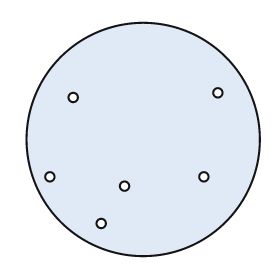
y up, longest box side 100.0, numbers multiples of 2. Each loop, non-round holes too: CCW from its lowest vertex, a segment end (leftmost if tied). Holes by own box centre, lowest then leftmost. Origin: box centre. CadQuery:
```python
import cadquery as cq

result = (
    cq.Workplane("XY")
    .moveTo(0.0, 0.0)
    .circle(50.0)
    .moveTo(-18.0, -36.0)
    .circle(2.0)
    .moveTo(-8.0, -20.0)
    .circle(2.0)
    .moveTo(-40.0, -16.0)
    .circle(2.0)
    .moveTo(26.0, -16.0)
    .circle(2.0)
    .moveTo(-30.0, 18.0)
    .circle(2.0)
    .moveTo(32.0, 20.0)
    .circle(2.0)
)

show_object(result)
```